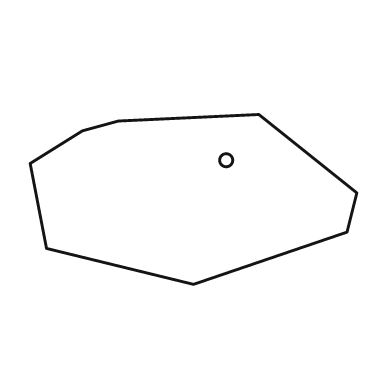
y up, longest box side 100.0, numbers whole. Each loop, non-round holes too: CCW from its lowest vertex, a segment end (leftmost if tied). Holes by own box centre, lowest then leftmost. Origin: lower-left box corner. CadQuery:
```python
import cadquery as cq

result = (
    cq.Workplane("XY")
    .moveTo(50.0, 0.0)
    .lineTo(97.0, 16.0)
    .lineTo(100.0, 28.0)
    .lineTo(70.0, 52.0)
    .lineTo(27.0, 50.0)
    .lineTo(16.0, 47.0)
    .lineTo(0.0, 37.0)
    .lineTo(5.0, 11.0)
    .close()
    .moveTo(60.0, 38.0)
    .circle(2.0)
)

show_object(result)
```